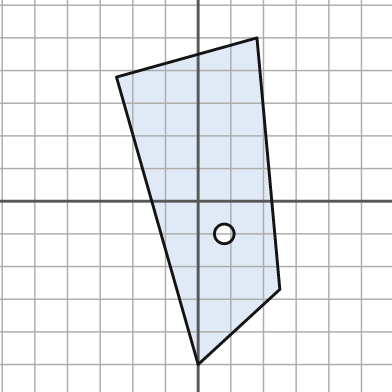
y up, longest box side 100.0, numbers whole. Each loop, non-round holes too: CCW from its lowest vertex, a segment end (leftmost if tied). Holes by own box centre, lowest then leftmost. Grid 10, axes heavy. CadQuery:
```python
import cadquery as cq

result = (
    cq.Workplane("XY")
    .moveTo(0.0, -50.0)
    .lineTo(25.0, -27.0)
    .lineTo(18.0, 50.0)
    .lineTo(-25.0, 38.0)
    .close()
    .moveTo(8.0, -10.0)
    .circle(3.0)
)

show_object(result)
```